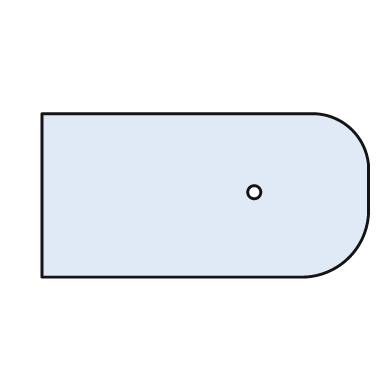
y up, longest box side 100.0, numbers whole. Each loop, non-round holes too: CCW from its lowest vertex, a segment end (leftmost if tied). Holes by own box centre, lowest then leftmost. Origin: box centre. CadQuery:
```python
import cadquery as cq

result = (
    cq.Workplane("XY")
    .moveTo(-50.0, -25.0)
    .lineTo(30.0, -25.0)
    .threePointArc((44.0, -19.0), (50.0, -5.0))
    .lineTo(50.0, 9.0)
    .threePointArc((45.0, 20.0), (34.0, 25.0))
    .lineTo(-50.0, 25.0)
    .close()
    .moveTo(15.0, 1.0)
    .circle(2.0)
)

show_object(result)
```